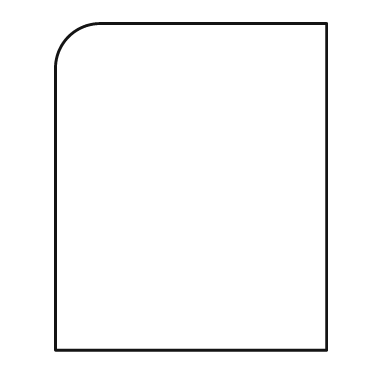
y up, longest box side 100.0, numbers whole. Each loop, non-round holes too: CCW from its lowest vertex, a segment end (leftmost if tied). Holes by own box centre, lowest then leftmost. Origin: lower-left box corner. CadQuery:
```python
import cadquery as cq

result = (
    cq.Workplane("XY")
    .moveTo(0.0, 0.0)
    .lineTo(83.0, 0.0)
    .lineTo(83.0, 100.0)
    .lineTo(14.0, 100.0)
    .threePointArc((4.0, 96.0), (0.0, 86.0))
    .close()
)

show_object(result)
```